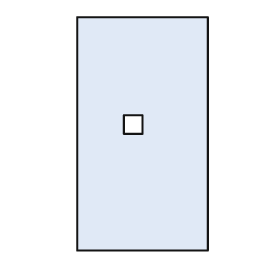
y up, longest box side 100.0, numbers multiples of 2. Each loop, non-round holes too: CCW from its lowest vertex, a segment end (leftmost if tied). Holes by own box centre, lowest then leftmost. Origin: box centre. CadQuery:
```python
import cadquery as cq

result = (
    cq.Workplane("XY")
    .moveTo(-28.0, -50.0)
    .lineTo(28.0, -50.0)
    .lineTo(28.0, 50.0)
    .lineTo(-28.0, 50.0)
    .close()
    .moveTo(-8.0, 0.0)
    .lineTo(0.0, 0.0)
    .lineTo(0.0, 8.0)
    .lineTo(-8.0, 8.0)
    .close()
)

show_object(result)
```